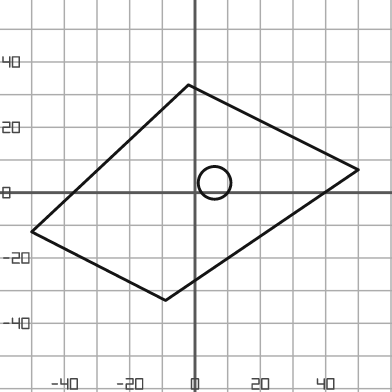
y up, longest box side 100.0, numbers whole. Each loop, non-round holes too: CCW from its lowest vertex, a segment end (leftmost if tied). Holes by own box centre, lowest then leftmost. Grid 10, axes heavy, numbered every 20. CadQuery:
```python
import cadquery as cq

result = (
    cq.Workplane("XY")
    .moveTo(-9.0, -33.0)
    .lineTo(50.0, 7.0)
    .lineTo(-2.0, 33.0)
    .lineTo(-50.0, -12.0)
    .close()
    .moveTo(6.0, 3.0)
    .circle(5.0)
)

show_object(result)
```